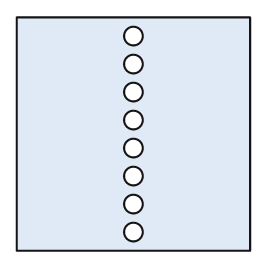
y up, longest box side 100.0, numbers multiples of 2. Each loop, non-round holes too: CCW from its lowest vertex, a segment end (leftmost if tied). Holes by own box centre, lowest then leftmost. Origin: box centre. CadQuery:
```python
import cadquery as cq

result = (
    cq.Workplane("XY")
    .moveTo(-50.0, -50.0)
    .lineTo(50.0, -50.0)
    .lineTo(50.0, 50.0)
    .lineTo(-50.0, 50.0)
    .close()
    .moveTo(0.0, -42.0)
    .circle(4.0)
    .moveTo(0.0, -30.0)
    .circle(4.0)
    .moveTo(0.0, -18.0)
    .circle(4.0)
    .moveTo(0.0, -6.0)
    .circle(4.0)
    .moveTo(0.0, 6.0)
    .circle(4.0)
    .moveTo(0.0, 18.0)
    .circle(4.0)
    .moveTo(0.0, 30.0)
    .circle(4.0)
    .moveTo(0.0, 42.0)
    .circle(4.0)
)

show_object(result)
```